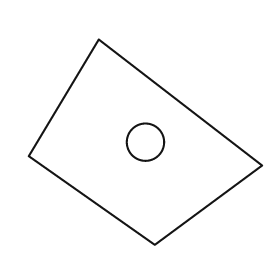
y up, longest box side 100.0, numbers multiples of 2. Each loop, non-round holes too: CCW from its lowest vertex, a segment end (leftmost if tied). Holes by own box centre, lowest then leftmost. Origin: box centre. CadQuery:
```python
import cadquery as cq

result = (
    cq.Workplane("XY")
    .moveTo(4.0, -44.0)
    .lineTo(50.0, -10.0)
    .lineTo(-20.0, 44.0)
    .lineTo(-50.0, -6.0)
    .close()
    .moveTo(0.0, 0.0)
    .circle(8.0)
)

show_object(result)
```